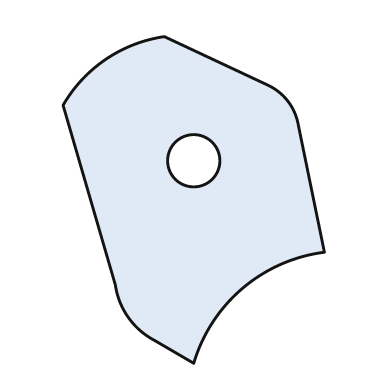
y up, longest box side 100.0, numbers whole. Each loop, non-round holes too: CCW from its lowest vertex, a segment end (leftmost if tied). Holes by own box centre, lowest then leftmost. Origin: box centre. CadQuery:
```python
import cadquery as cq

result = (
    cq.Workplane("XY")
    .moveTo(0.0, -50.0)
    .threePointArc((15.0, -27.0), (40.0, -16.0))
    .lineTo(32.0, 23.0)
    .threePointArc((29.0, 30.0), (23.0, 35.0))
    .lineTo(-9.0, 50.0)
    .threePointArc((-27.0, 43.0), (-40.0, 29.0))
    .lineTo(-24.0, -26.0)
    .threePointArc((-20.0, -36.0), (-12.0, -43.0))
    .close()
    .moveTo(0.0, 12.0)
    .circle(8.0)
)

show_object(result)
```